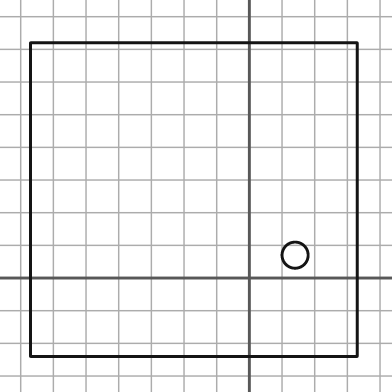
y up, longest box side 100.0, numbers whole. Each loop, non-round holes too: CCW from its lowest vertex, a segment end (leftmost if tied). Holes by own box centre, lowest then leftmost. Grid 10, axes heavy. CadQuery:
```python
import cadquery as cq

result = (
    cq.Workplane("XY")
    .moveTo(-67.0, -24.0)
    .lineTo(33.0, -24.0)
    .lineTo(33.0, 72.0)
    .lineTo(-67.0, 72.0)
    .close()
    .moveTo(14.0, 7.0)
    .circle(4.0)
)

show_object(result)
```